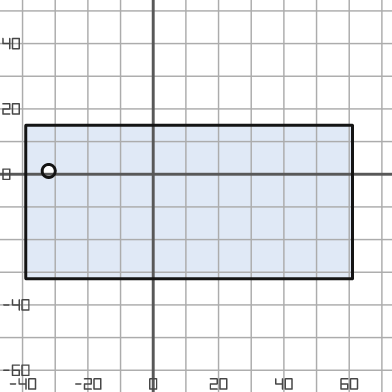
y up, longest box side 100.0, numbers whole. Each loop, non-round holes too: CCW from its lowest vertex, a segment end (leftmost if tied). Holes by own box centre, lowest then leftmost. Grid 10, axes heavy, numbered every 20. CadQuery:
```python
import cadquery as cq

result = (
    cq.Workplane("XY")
    .moveTo(-39.0, -32.0)
    .lineTo(61.0, -32.0)
    .lineTo(61.0, 15.0)
    .lineTo(-39.0, 15.0)
    .close()
    .moveTo(-32.0, 1.0)
    .circle(2.0)
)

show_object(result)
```